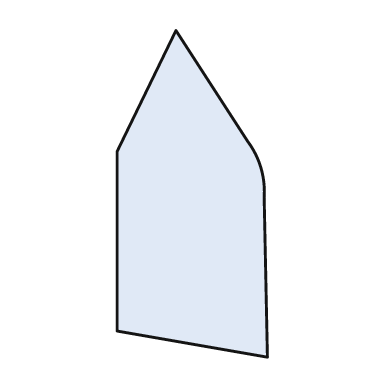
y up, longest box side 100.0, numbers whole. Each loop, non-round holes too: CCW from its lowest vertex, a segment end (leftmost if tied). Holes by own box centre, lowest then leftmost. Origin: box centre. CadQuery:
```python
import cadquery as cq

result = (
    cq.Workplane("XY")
    .moveTo(23.0, -50.0)
    .lineTo(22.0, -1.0)
    .threePointArc((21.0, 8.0), (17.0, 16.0))
    .lineTo(-5.0, 50.0)
    .lineTo(-23.0, 13.0)
    .lineTo(-23.0, -42.0)
    .close()
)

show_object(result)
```